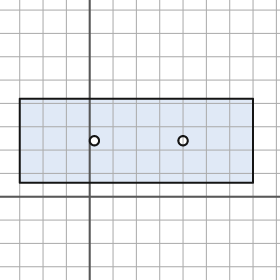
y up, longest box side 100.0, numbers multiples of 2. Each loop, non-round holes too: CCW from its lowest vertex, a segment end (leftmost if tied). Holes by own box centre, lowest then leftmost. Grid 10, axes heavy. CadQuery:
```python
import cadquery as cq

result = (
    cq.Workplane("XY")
    .moveTo(-30.0, 6.0)
    .lineTo(70.0, 6.0)
    .lineTo(70.0, 42.0)
    .lineTo(-30.0, 42.0)
    .close()
    .moveTo(2.0, 24.0)
    .circle(2.0)
    .moveTo(40.0, 24.0)
    .circle(2.0)
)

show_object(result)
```